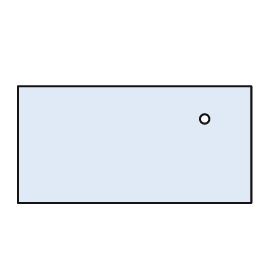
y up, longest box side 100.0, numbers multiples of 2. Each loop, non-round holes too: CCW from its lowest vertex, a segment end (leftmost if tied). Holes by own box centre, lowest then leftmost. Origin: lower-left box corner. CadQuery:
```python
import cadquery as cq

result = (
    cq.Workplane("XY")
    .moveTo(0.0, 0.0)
    .lineTo(100.0, 0.0)
    .lineTo(100.0, 50.0)
    .lineTo(0.0, 50.0)
    .close()
    .moveTo(80.0, 36.0)
    .circle(2.0)
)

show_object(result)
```